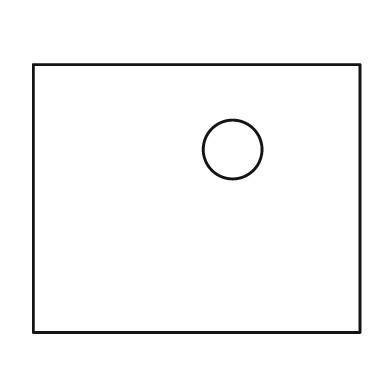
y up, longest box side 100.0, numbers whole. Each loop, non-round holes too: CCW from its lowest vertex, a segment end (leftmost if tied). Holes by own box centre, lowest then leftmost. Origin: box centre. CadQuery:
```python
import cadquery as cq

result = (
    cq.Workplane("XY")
    .moveTo(-50.0, -41.0)
    .lineTo(50.0, -41.0)
    .lineTo(50.0, 41.0)
    .lineTo(-50.0, 41.0)
    .close()
    .moveTo(11.0, 15.0)
    .circle(9.0)
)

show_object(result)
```